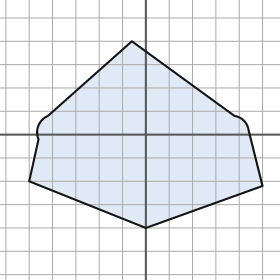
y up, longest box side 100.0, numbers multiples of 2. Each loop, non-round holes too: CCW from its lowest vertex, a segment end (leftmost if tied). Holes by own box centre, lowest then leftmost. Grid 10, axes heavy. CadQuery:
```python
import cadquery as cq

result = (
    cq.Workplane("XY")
    .moveTo(0.0, -40.0)
    .lineTo(50.0, -22.0)
    .lineTo(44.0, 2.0)
    .threePointArc((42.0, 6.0), (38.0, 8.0))
    .lineTo(-6.0, 40.0)
    .lineTo(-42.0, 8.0)
    .threePointArc((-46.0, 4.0), (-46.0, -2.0))
    .lineTo(-50.0, -20.0)
    .close()
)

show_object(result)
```